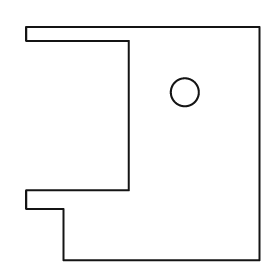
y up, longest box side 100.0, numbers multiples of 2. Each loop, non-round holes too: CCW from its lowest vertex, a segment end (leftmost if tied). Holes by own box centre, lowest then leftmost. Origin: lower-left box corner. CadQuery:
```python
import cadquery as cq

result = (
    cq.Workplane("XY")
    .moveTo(16.0, 0.0)
    .lineTo(100.0, 0.0)
    .lineTo(100.0, 100.0)
    .lineTo(0.0, 100.0)
    .lineTo(0.0, 94.0)
    .lineTo(44.0, 94.0)
    .lineTo(44.0, 30.0)
    .lineTo(0.0, 30.0)
    .lineTo(0.0, 22.0)
    .lineTo(16.0, 22.0)
    .close()
    .moveTo(68.0, 72.0)
    .circle(6.0)
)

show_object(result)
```